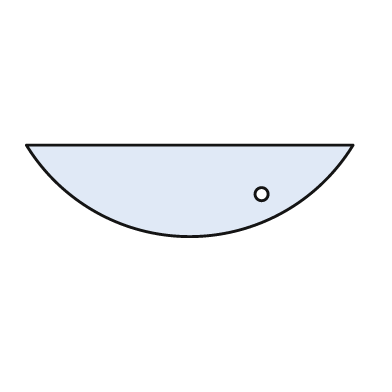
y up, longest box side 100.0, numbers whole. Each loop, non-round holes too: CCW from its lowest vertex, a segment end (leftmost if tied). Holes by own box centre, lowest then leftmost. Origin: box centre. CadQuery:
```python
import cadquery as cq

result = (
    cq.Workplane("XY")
    .moveTo(-50.0, 14.0)
    .threePointArc((0.0, -14.0), (50.0, 14.0))
    .close()
    .moveTo(22.0, -1.0)
    .circle(2.0)
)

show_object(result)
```